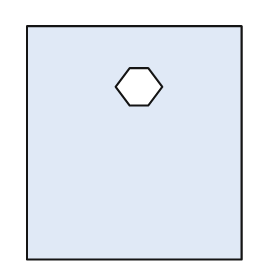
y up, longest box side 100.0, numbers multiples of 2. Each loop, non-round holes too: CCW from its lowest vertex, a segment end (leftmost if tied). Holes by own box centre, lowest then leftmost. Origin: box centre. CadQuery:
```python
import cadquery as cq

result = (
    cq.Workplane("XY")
    .moveTo(-46.0, -50.0)
    .lineTo(46.0, -50.0)
    .lineTo(46.0, 50.0)
    .lineTo(-46.0, 50.0)
    .close()
    .moveTo(-2.0, 16.0)
    .lineTo(6.0, 16.0)
    .lineTo(12.0, 24.0)
    .lineTo(6.0, 32.0)
    .lineTo(-2.0, 32.0)
    .lineTo(-8.0, 24.0)
    .close()
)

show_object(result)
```